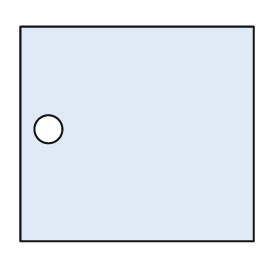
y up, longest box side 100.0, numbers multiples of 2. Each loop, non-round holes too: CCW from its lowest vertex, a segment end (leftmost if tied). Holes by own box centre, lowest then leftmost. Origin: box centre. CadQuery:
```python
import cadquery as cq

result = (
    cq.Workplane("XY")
    .moveTo(-50.0, -46.0)
    .lineTo(50.0, -46.0)
    .lineTo(50.0, 46.0)
    .lineTo(-50.0, 46.0)
    .close()
    .moveTo(-38.0, 2.0)
    .circle(6.0)
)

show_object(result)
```